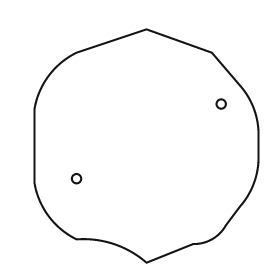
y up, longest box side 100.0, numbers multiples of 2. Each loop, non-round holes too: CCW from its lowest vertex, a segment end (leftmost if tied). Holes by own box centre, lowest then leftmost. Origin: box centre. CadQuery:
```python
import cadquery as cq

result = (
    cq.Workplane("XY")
    .moveTo(0.0, -50.0)
    .lineTo(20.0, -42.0)
    .threePointArc((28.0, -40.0), (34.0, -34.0))
    .lineTo(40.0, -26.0)
    .threePointArc((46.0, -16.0), (48.0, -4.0))
    .lineTo(48.0, 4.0)
    .threePointArc((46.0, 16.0), (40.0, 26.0))
    .lineTo(28.0, 40.0)
    .lineTo(0.0, 50.0)
    .lineTo(-30.0, 40.0)
    .threePointArc((-42.0, 30.0), (-48.0, 16.0))
    .lineTo(-48.0, -16.0)
    .threePointArc((-42.0, -30.0), (-30.0, -40.0))
    .threePointArc((-14.0, -42.0), (0.0, -50.0))
    .close()
    .moveTo(-30.0, -14.0)
    .circle(2.0)
    .moveTo(32.0, 18.0)
    .circle(2.0)
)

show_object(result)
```